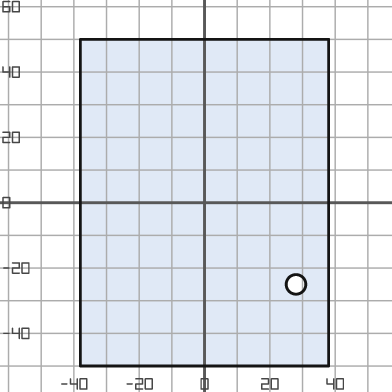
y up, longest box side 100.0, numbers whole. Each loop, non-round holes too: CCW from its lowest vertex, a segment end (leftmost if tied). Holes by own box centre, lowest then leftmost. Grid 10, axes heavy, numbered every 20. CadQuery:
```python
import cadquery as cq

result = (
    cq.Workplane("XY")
    .moveTo(-38.0, -50.0)
    .lineTo(38.0, -50.0)
    .lineTo(38.0, 50.0)
    .lineTo(-38.0, 50.0)
    .close()
    .moveTo(28.0, -25.0)
    .circle(3.0)
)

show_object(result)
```